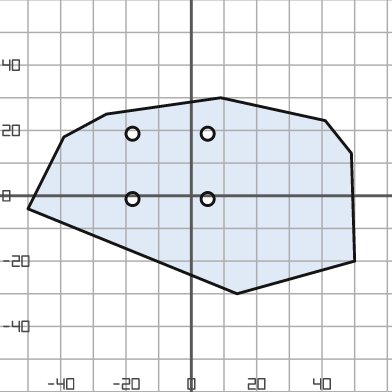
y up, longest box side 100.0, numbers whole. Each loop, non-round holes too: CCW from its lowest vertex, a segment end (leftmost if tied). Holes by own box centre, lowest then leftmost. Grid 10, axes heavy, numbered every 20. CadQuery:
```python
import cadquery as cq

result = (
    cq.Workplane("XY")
    .moveTo(14.0, -30.0)
    .lineTo(50.0, -20.0)
    .lineTo(49.0, 13.0)
    .lineTo(41.0, 23.0)
    .lineTo(9.0, 30.0)
    .lineTo(-26.0, 25.0)
    .lineTo(-39.0, 18.0)
    .lineTo(-50.0, -4.0)
    .close()
    .moveTo(-18.0, -1.0)
    .circle(2.0)
    .moveTo(5.0, -1.0)
    .circle(2.0)
    .moveTo(-18.0, 19.0)
    .circle(2.0)
    .moveTo(5.0, 19.0)
    .circle(2.0)
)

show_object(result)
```